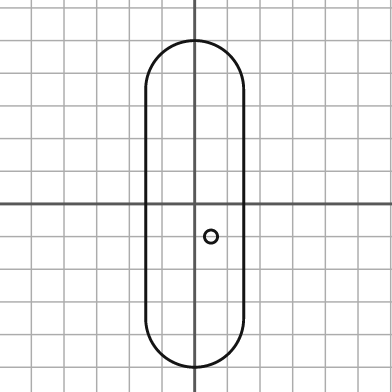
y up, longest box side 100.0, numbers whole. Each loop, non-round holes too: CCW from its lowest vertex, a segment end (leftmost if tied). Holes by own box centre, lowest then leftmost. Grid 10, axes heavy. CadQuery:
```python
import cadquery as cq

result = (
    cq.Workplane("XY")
    .moveTo(-15.0, -35.0)
    .threePointArc((0.0, -50.0), (15.0, -35.0))
    .lineTo(15.0, 35.0)
    .threePointArc((0.0, 50.0), (-15.0, 35.0))
    .close()
    .moveTo(5.0, -10.0)
    .circle(2.0)
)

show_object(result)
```